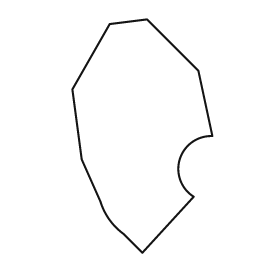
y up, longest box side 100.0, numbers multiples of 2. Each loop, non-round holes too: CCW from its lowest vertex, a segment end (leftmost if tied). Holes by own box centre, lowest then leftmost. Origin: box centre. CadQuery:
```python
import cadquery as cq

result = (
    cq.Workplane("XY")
    .moveTo(0.0, -50.0)
    .lineTo(22.0, -26.0)
    .threePointArc((16.0, -10.0), (30.0, 0.0))
    .lineTo(24.0, 28.0)
    .lineTo(2.0, 50.0)
    .lineTo(-14.0, 48.0)
    .lineTo(-30.0, 20.0)
    .lineTo(-26.0, -10.0)
    .lineTo(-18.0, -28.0)
    .threePointArc((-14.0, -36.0), (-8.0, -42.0))
    .close()
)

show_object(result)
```